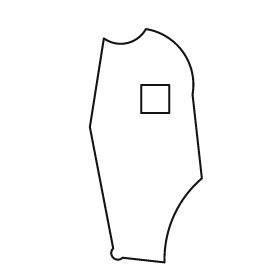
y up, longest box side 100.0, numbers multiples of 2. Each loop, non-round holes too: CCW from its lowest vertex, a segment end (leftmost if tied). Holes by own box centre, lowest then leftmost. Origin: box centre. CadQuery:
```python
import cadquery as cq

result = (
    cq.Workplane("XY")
    .moveTo(8.0, -50.0)
    .threePointArc((12.0, -30.0), (24.0, -14.0))
    .lineTo(20.0, 22.0)
    .threePointArc((16.0, 40.0), (0.0, 50.0))
    .threePointArc((-8.0, 44.0), (-18.0, 46.0))
    .lineTo(-24.0, 8.0)
    .lineTo(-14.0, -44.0)
    .threePointArc((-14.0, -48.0), (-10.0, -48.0))
    .close()
    .moveTo(-2.0, 14.0)
    .lineTo(10.0, 14.0)
    .lineTo(10.0, 26.0)
    .lineTo(-2.0, 26.0)
    .close()
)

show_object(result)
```